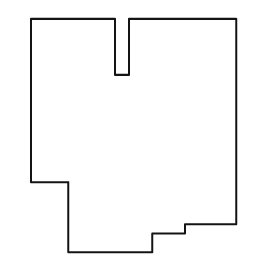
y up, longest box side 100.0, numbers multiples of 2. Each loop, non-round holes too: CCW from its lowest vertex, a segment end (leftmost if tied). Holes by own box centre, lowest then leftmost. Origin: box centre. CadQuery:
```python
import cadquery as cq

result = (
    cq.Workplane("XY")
    .moveTo(-28.0, -50.0)
    .lineTo(8.0, -50.0)
    .lineTo(8.0, -42.0)
    .lineTo(22.0, -42.0)
    .lineTo(22.0, -38.0)
    .lineTo(44.0, -38.0)
    .lineTo(44.0, 50.0)
    .lineTo(-2.0, 50.0)
    .lineTo(-2.0, 26.0)
    .lineTo(-8.0, 26.0)
    .lineTo(-8.0, 50.0)
    .lineTo(-44.0, 50.0)
    .lineTo(-44.0, -20.0)
    .lineTo(-28.0, -20.0)
    .close()
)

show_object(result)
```